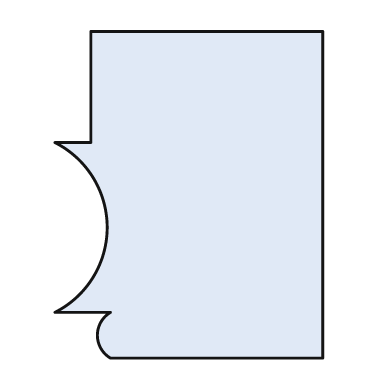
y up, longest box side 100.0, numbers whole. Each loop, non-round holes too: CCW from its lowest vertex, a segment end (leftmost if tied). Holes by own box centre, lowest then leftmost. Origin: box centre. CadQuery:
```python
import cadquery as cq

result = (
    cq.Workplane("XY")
    .moveTo(-24.0, -50.0)
    .lineTo(41.0, -50.0)
    .lineTo(41.0, 50.0)
    .lineTo(-30.0, 50.0)
    .lineTo(-30.0, 16.0)
    .lineTo(-41.0, 16.0)
    .threePointArc((-25.0, -10.0), (-41.0, -36.0))
    .lineTo(-24.0, -36.0)
    .threePointArc((-28.0, -43.0), (-24.0, -50.0))
    .close()
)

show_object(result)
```